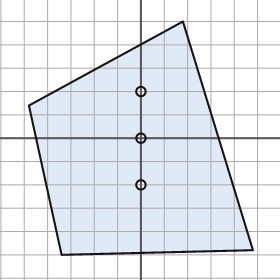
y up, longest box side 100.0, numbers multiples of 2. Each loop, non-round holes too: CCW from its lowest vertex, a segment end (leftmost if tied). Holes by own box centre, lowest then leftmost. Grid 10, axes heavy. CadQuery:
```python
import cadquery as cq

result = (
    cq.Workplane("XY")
    .moveTo(-34.0, -50.0)
    .lineTo(48.0, -48.0)
    .lineTo(18.0, 50.0)
    .lineTo(-48.0, 14.0)
    .close()
    .moveTo(0.0, -20.0)
    .circle(2.0)
    .moveTo(0.0, 0.0)
    .circle(2.0)
    .moveTo(0.0, 20.0)
    .circle(2.0)
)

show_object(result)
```